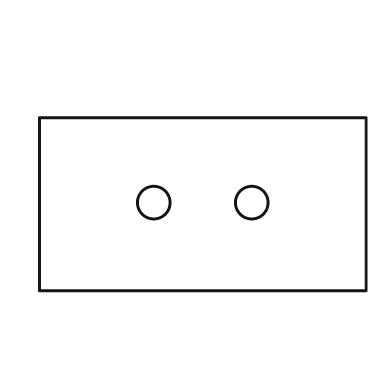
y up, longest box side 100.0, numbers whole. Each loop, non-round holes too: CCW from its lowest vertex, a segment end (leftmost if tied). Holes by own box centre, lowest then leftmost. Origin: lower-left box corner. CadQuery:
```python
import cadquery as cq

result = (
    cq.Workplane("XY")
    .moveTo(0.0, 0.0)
    .lineTo(100.0, 0.0)
    .lineTo(100.0, 53.0)
    .lineTo(0.0, 53.0)
    .close()
    .moveTo(35.0, 27.0)
    .circle(5.0)
    .moveTo(65.0, 27.0)
    .circle(5.0)
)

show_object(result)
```